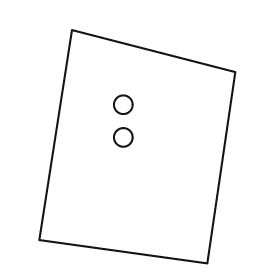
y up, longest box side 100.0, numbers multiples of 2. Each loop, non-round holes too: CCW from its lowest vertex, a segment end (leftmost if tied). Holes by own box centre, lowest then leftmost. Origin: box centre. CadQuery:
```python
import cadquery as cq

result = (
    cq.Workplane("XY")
    .moveTo(30.0, -50.0)
    .lineTo(42.0, 32.0)
    .lineTo(-28.0, 50.0)
    .lineTo(-42.0, -40.0)
    .close()
    .moveTo(-6.0, 4.0)
    .circle(4.0)
    .moveTo(-6.0, 18.0)
    .circle(4.0)
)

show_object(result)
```